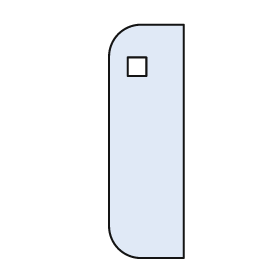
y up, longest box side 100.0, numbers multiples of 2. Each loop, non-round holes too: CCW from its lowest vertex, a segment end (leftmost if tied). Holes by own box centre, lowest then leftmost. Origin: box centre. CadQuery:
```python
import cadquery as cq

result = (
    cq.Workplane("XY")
    .moveTo(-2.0, -50.0)
    .lineTo(16.0, -50.0)
    .lineTo(16.0, 50.0)
    .lineTo(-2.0, 50.0)
    .threePointArc((-12.0, 46.0), (-16.0, 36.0))
    .lineTo(-16.0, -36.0)
    .threePointArc((-12.0, -46.0), (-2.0, -50.0))
    .close()
    .moveTo(-8.0, 28.0)
    .lineTo(0.0, 28.0)
    .lineTo(0.0, 36.0)
    .lineTo(-8.0, 36.0)
    .close()
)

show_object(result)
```